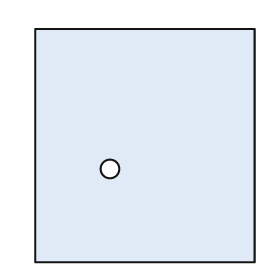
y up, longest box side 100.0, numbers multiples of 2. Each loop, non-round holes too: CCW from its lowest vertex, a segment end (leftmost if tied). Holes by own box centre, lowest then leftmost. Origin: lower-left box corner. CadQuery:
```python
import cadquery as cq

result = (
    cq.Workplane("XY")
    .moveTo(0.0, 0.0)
    .lineTo(94.0, 0.0)
    .lineTo(94.0, 100.0)
    .lineTo(0.0, 100.0)
    .close()
    .moveTo(32.0, 40.0)
    .circle(4.0)
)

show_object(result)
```